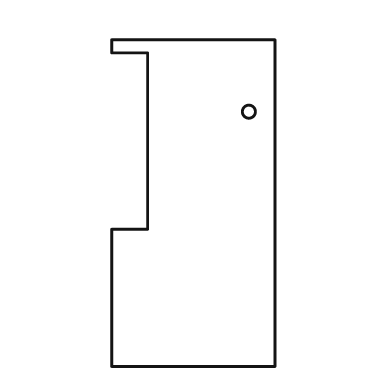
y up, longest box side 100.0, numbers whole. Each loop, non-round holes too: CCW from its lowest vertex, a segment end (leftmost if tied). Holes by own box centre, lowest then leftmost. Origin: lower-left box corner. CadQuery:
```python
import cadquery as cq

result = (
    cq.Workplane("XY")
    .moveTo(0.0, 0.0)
    .lineTo(50.0, 0.0)
    .lineTo(50.0, 100.0)
    .lineTo(0.0, 100.0)
    .lineTo(0.0, 96.0)
    .lineTo(11.0, 96.0)
    .lineTo(11.0, 42.0)
    .lineTo(0.0, 42.0)
    .close()
    .moveTo(42.0, 78.0)
    .circle(2.0)
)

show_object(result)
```